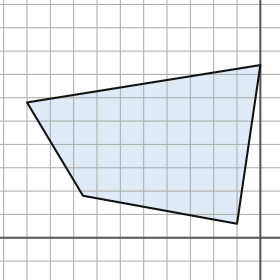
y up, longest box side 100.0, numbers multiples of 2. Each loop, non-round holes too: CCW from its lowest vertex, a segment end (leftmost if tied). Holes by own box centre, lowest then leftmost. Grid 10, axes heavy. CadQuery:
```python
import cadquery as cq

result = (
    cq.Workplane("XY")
    .moveTo(-10.0, 6.0)
    .lineTo(0.0, 74.0)
    .lineTo(-100.0, 58.0)
    .lineTo(-76.0, 18.0)
    .close()
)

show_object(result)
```